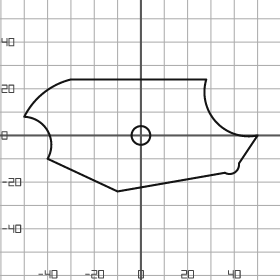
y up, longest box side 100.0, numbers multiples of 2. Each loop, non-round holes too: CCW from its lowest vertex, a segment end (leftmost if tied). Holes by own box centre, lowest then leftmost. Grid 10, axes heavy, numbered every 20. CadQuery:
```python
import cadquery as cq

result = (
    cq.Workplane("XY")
    .moveTo(-10.0, -24.0)
    .lineTo(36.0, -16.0)
    .threePointArc((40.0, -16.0), (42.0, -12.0))
    .lineTo(50.0, 0.0)
    .threePointArc((32.0, 6.0), (28.0, 24.0))
    .lineTo(-30.0, 24.0)
    .threePointArc((-42.0, 18.0), (-50.0, 8.0))
    .threePointArc((-40.0, 2.0), (-40.0, -10.0))
    .close()
    .moveTo(0.0, 0.0)
    .circle(4.0)
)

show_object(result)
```